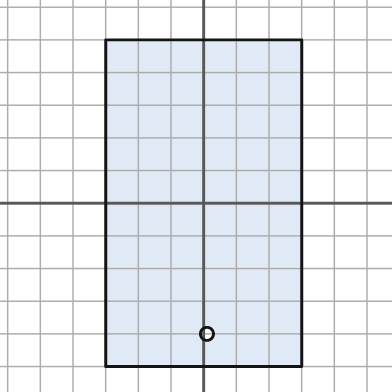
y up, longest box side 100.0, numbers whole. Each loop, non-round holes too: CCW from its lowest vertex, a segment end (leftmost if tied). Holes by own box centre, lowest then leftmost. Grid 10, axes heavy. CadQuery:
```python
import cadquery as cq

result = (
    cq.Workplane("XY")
    .moveTo(-30.0, -50.0)
    .lineTo(30.0, -50.0)
    .lineTo(30.0, 50.0)
    .lineTo(-30.0, 50.0)
    .close()
    .moveTo(1.0, -40.0)
    .circle(2.0)
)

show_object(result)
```